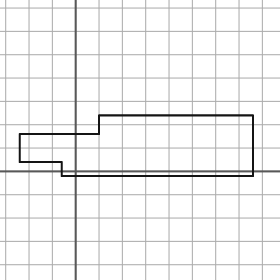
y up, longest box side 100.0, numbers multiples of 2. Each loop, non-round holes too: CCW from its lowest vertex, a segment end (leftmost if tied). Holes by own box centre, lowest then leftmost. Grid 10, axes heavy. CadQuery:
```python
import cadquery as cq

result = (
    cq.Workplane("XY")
    .moveTo(-6.0, -2.0)
    .lineTo(76.0, -2.0)
    .lineTo(76.0, 24.0)
    .lineTo(10.0, 24.0)
    .lineTo(10.0, 16.0)
    .lineTo(-24.0, 16.0)
    .lineTo(-24.0, 4.0)
    .lineTo(-6.0, 4.0)
    .close()
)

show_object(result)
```